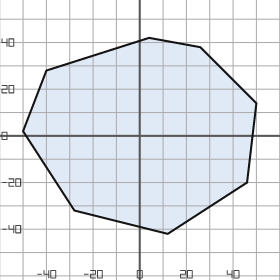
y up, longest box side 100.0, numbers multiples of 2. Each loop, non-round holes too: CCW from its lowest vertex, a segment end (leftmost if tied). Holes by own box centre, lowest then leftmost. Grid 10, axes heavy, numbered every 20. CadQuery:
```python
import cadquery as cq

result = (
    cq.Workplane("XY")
    .moveTo(12.0, -42.0)
    .lineTo(46.0, -20.0)
    .lineTo(50.0, 14.0)
    .lineTo(26.0, 38.0)
    .lineTo(4.0, 42.0)
    .lineTo(-40.0, 28.0)
    .lineTo(-50.0, 2.0)
    .lineTo(-28.0, -32.0)
    .close()
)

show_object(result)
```